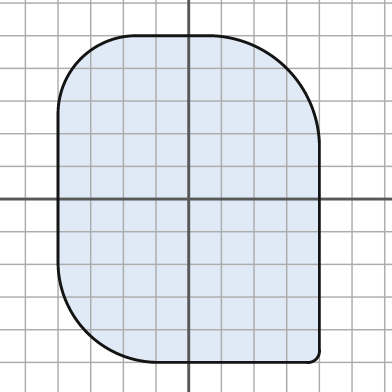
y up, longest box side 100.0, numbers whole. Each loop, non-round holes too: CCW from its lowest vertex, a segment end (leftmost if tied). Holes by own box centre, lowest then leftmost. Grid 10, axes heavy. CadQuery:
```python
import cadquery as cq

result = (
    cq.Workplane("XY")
    .moveTo(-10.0, -50.0)
    .lineTo(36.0, -50.0)
    .threePointArc((39.0, -49.0), (40.0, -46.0))
    .lineTo(40.0, 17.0)
    .threePointArc((30.0, 40.0), (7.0, 50.0))
    .lineTo(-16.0, 50.0)
    .threePointArc((-33.0, 43.0), (-40.0, 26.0))
    .lineTo(-40.0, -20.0)
    .threePointArc((-31.0, -41.0), (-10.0, -50.0))
    .close()
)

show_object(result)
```